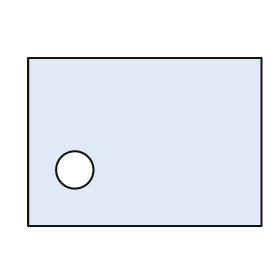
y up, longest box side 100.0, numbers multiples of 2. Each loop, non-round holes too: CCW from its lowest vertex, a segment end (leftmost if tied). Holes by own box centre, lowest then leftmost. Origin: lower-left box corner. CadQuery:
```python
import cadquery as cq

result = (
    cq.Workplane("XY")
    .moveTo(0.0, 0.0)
    .lineTo(100.0, 0.0)
    .lineTo(100.0, 72.0)
    .lineTo(0.0, 72.0)
    .close()
    .moveTo(20.0, 24.0)
    .circle(8.0)
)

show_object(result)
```